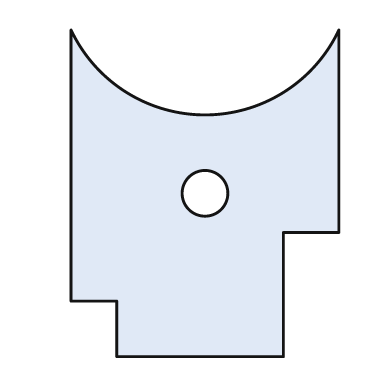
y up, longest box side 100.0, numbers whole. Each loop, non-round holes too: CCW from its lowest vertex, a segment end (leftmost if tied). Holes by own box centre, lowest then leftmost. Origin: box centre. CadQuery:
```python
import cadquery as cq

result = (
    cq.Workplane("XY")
    .moveTo(-27.0, -50.0)
    .lineTo(24.0, -50.0)
    .lineTo(24.0, -12.0)
    .lineTo(41.0, -12.0)
    .lineTo(41.0, 50.0)
    .threePointArc((0.0, 24.0), (-41.0, 50.0))
    .lineTo(-41.0, -33.0)
    .lineTo(-27.0, -33.0)
    .close()
    .moveTo(0.0, 0.0)
    .circle(7.0)
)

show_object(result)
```